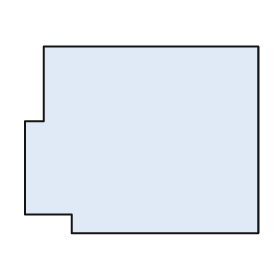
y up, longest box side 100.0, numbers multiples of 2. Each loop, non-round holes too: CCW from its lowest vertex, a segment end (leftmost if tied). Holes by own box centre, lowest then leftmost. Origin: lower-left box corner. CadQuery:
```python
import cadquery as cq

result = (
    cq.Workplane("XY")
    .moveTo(20.0, 0.0)
    .lineTo(100.0, 0.0)
    .lineTo(100.0, 80.0)
    .lineTo(8.0, 80.0)
    .lineTo(8.0, 48.0)
    .lineTo(0.0, 48.0)
    .lineTo(0.0, 8.0)
    .lineTo(20.0, 8.0)
    .close()
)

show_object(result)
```